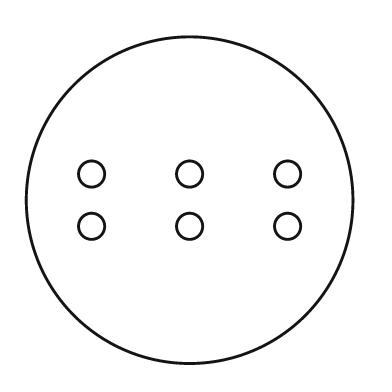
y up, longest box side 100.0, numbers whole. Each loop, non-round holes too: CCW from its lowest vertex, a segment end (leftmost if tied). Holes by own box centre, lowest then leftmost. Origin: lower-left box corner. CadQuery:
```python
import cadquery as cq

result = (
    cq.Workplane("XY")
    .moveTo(50.0, 50.0)
    .circle(50.0)
    .moveTo(20.0, 42.0)
    .circle(4.0)
    .moveTo(50.0, 42.0)
    .circle(4.0)
    .moveTo(80.0, 42.0)
    .circle(4.0)
    .moveTo(20.0, 58.0)
    .circle(4.0)
    .moveTo(50.0, 58.0)
    .circle(4.0)
    .moveTo(80.0, 58.0)
    .circle(4.0)
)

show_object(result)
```